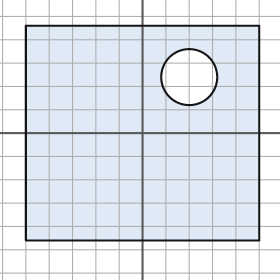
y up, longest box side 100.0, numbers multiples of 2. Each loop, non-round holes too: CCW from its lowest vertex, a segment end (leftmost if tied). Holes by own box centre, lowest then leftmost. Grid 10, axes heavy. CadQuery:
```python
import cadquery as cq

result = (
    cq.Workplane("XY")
    .moveTo(-50.0, -46.0)
    .lineTo(50.0, -46.0)
    .lineTo(50.0, 46.0)
    .lineTo(-50.0, 46.0)
    .close()
    .moveTo(20.0, 24.0)
    .circle(12.0)
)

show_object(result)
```